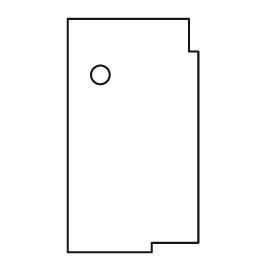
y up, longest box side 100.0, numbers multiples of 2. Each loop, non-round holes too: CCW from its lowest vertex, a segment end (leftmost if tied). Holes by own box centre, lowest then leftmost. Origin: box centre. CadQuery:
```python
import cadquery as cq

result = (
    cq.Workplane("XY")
    .moveTo(-28.0, -50.0)
    .lineTo(8.0, -50.0)
    .lineTo(8.0, -46.0)
    .lineTo(28.0, -46.0)
    .lineTo(28.0, 36.0)
    .lineTo(24.0, 36.0)
    .lineTo(24.0, 50.0)
    .lineTo(-28.0, 50.0)
    .close()
    .moveTo(-14.0, 26.0)
    .circle(4.0)
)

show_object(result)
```